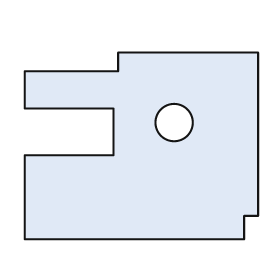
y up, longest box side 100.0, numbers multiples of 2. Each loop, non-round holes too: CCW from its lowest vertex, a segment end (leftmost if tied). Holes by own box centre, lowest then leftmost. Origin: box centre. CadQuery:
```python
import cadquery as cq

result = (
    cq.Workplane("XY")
    .moveTo(-50.0, -40.0)
    .lineTo(44.0, -40.0)
    .lineTo(44.0, -30.0)
    .lineTo(50.0, -30.0)
    .lineTo(50.0, 40.0)
    .lineTo(-10.0, 40.0)
    .lineTo(-10.0, 32.0)
    .lineTo(-50.0, 32.0)
    .lineTo(-50.0, 16.0)
    .lineTo(-12.0, 16.0)
    .lineTo(-12.0, -4.0)
    .lineTo(-50.0, -4.0)
    .close()
    .moveTo(14.0, 10.0)
    .circle(8.0)
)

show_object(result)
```